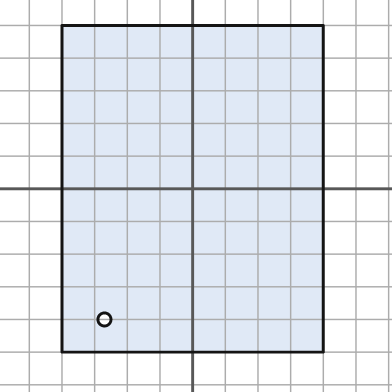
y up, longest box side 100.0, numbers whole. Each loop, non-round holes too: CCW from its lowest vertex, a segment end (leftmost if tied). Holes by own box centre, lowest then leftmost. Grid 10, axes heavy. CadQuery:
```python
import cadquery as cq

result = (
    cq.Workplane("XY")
    .moveTo(-40.0, -50.0)
    .lineTo(40.0, -50.0)
    .lineTo(40.0, 50.0)
    .lineTo(-40.0, 50.0)
    .close()
    .moveTo(-27.0, -40.0)
    .circle(2.0)
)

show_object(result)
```